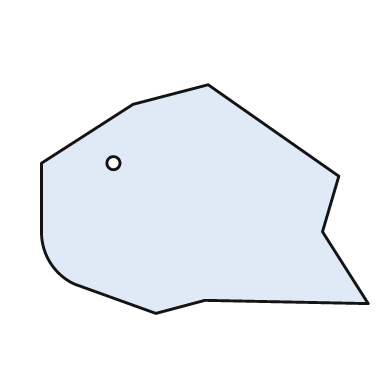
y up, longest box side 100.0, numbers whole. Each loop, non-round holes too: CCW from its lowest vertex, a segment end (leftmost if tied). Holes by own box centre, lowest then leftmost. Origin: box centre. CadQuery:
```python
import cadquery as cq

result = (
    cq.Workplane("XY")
    .moveTo(-15.0, -35.0)
    .lineTo(0.0, -31.0)
    .lineTo(50.0, -32.0)
    .lineTo(36.0, -10.0)
    .lineTo(41.0, 7.0)
    .lineTo(1.0, 35.0)
    .lineTo(-22.0, 29.0)
    .lineTo(-50.0, 11.0)
    .lineTo(-50.0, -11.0)
    .threePointArc((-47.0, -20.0), (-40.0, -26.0))
    .close()
    .moveTo(-28.0, 11.0)
    .circle(2.0)
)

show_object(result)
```